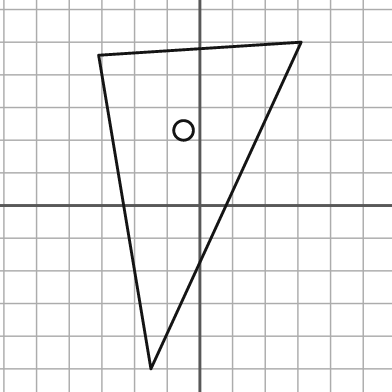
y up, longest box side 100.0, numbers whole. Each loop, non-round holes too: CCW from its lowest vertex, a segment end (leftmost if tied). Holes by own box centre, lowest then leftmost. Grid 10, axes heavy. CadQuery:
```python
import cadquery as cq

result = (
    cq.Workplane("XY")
    .moveTo(-15.0, -50.0)
    .lineTo(31.0, 50.0)
    .lineTo(-31.0, 46.0)
    .close()
    .moveTo(-5.0, 23.0)
    .circle(3.0)
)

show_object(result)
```